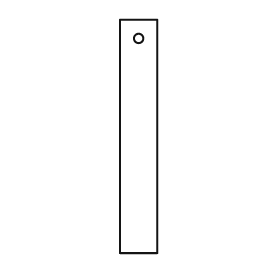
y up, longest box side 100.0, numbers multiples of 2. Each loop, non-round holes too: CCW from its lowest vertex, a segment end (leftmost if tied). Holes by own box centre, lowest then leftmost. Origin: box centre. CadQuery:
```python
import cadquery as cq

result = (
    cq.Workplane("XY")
    .moveTo(-8.0, -50.0)
    .lineTo(8.0, -50.0)
    .lineTo(8.0, 50.0)
    .lineTo(-8.0, 50.0)
    .close()
    .moveTo(0.0, 42.0)
    .circle(2.0)
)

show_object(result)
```